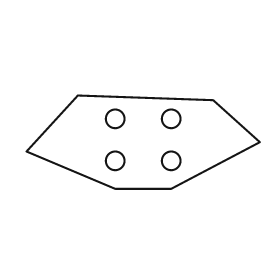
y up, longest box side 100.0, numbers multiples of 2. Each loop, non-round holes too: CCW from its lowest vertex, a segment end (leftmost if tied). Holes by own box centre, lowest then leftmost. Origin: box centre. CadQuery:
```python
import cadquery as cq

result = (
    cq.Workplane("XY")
    .moveTo(-12.0, -20.0)
    .lineTo(12.0, -20.0)
    .lineTo(50.0, 0.0)
    .lineTo(30.0, 18.0)
    .lineTo(-28.0, 20.0)
    .lineTo(-50.0, -4.0)
    .close()
    .moveTo(-12.0, -8.0)
    .circle(4.0)
    .moveTo(12.0, -8.0)
    .circle(4.0)
    .moveTo(-12.0, 10.0)
    .circle(4.0)
    .moveTo(12.0, 10.0)
    .circle(4.0)
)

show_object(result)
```